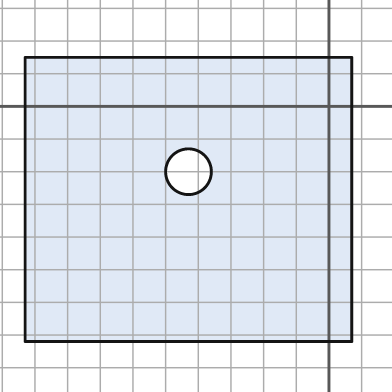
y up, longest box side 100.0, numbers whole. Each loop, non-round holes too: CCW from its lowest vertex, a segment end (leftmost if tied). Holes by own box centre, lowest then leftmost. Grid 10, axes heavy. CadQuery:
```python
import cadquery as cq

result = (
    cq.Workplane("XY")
    .moveTo(-93.0, -72.0)
    .lineTo(7.0, -72.0)
    .lineTo(7.0, 15.0)
    .lineTo(-93.0, 15.0)
    .close()
    .moveTo(-43.0, -20.0)
    .circle(7.0)
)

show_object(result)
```